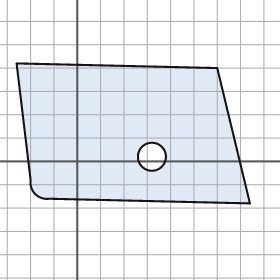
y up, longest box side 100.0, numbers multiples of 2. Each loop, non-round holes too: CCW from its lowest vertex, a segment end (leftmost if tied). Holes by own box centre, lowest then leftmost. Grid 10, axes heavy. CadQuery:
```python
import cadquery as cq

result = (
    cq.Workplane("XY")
    .moveTo(74.0, -18.0)
    .lineTo(60.0, 40.0)
    .lineTo(-26.0, 42.0)
    .lineTo(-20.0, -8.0)
    .threePointArc((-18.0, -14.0), (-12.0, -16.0))
    .close()
    .moveTo(32.0, 2.0)
    .circle(6.0)
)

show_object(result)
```